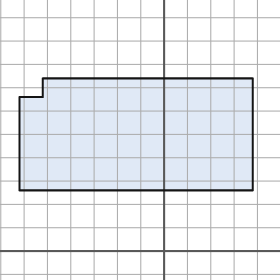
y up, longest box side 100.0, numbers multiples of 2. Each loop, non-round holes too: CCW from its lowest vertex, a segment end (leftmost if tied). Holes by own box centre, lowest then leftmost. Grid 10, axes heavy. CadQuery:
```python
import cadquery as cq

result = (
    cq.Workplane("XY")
    .moveTo(-62.0, 26.0)
    .lineTo(38.0, 26.0)
    .lineTo(38.0, 74.0)
    .lineTo(-52.0, 74.0)
    .lineTo(-52.0, 66.0)
    .lineTo(-62.0, 66.0)
    .close()
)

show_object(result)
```